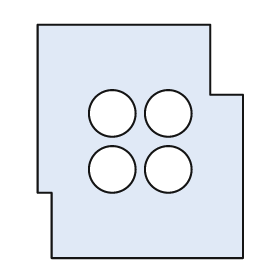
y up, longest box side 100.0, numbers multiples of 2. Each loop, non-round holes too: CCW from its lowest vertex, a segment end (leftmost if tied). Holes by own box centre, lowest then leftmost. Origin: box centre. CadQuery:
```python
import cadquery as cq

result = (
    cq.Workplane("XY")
    .moveTo(-38.0, -50.0)
    .lineTo(44.0, -50.0)
    .lineTo(44.0, 20.0)
    .lineTo(30.0, 20.0)
    .lineTo(30.0, 50.0)
    .lineTo(-44.0, 50.0)
    .lineTo(-44.0, -22.0)
    .lineTo(-38.0, -22.0)
    .close()
    .moveTo(-12.0, -12.0)
    .circle(10.0)
    .moveTo(12.0, -12.0)
    .circle(10.0)
    .moveTo(-12.0, 12.0)
    .circle(10.0)
    .moveTo(12.0, 12.0)
    .circle(10.0)
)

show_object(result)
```